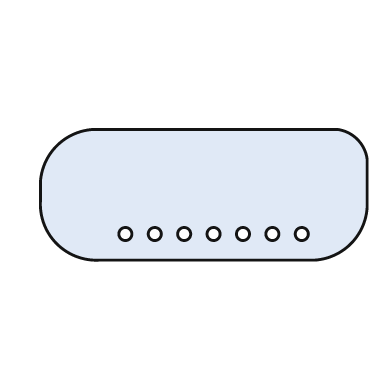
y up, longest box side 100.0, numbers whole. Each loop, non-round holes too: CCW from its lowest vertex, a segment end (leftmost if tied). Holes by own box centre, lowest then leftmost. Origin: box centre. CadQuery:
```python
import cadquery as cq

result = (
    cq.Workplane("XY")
    .moveTo(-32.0, -20.0)
    .lineTo(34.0, -20.0)
    .threePointArc((45.0, -15.0), (50.0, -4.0))
    .lineTo(50.0, 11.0)
    .threePointArc((47.0, 17.0), (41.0, 20.0))
    .lineTo(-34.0, 20.0)
    .threePointArc((-45.0, 15.0), (-50.0, 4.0))
    .lineTo(-50.0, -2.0)
    .threePointArc((-45.0, -15.0), (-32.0, -20.0))
    .close()
    .moveTo(-24.0, -12.0)
    .circle(2.0)
    .moveTo(-15.0, -12.0)
    .circle(2.0)
    .moveTo(-6.0, -12.0)
    .circle(2.0)
    .moveTo(3.0, -12.0)
    .circle(2.0)
    .moveTo(12.0, -12.0)
    .circle(2.0)
    .moveTo(21.0, -12.0)
    .circle(2.0)
    .moveTo(30.0, -12.0)
    .circle(2.0)
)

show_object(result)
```